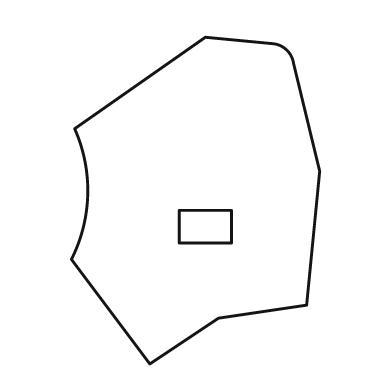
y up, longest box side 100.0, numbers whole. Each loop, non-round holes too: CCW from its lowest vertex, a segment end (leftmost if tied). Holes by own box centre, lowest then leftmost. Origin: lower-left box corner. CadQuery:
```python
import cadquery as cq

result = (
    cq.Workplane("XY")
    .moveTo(24.0, 0.0)
    .lineTo(45.0, 14.0)
    .lineTo(72.0, 18.0)
    .lineTo(76.0, 59.0)
    .lineTo(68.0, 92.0)
    .threePointArc((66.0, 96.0), (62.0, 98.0))
    .lineTo(41.0, 100.0)
    .lineTo(1.0, 72.0)
    .threePointArc((5.0, 52.0), (0.0, 32.0))
    .close()
    .moveTo(33.0, 37.0)
    .lineTo(49.0, 37.0)
    .lineTo(49.0, 47.0)
    .lineTo(33.0, 47.0)
    .close()
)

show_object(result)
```